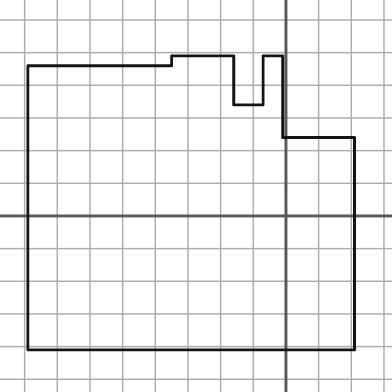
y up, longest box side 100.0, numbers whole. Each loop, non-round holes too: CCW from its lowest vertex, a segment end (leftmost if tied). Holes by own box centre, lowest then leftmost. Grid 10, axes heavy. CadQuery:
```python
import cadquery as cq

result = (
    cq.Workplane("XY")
    .moveTo(-79.0, -41.0)
    .lineTo(21.0, -41.0)
    .lineTo(21.0, 24.0)
    .lineTo(-1.0, 24.0)
    .lineTo(-1.0, 49.0)
    .lineTo(-7.0, 49.0)
    .lineTo(-7.0, 34.0)
    .lineTo(-16.0, 34.0)
    .lineTo(-16.0, 49.0)
    .lineTo(-35.0, 49.0)
    .lineTo(-35.0, 46.0)
    .lineTo(-79.0, 46.0)
    .close()
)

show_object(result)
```